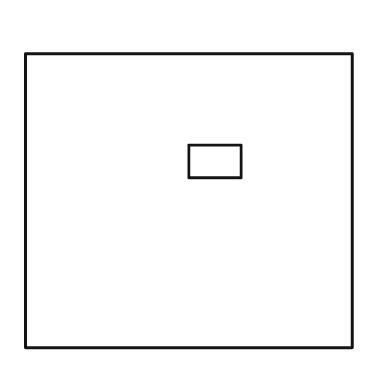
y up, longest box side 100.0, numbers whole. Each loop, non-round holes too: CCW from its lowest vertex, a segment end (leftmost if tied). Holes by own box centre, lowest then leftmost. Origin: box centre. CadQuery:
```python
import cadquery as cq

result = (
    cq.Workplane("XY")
    .moveTo(-50.0, -45.0)
    .lineTo(50.0, -45.0)
    .lineTo(50.0, 45.0)
    .lineTo(-50.0, 45.0)
    .close()
    .moveTo(0.0, 7.0)
    .lineTo(16.0, 7.0)
    .lineTo(16.0, 17.0)
    .lineTo(0.0, 17.0)
    .close()
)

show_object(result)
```